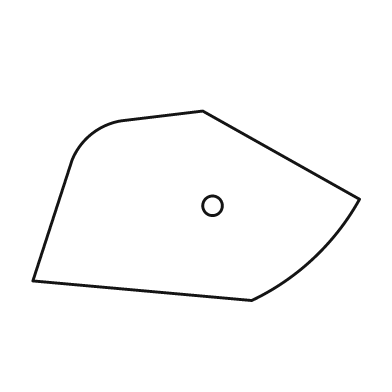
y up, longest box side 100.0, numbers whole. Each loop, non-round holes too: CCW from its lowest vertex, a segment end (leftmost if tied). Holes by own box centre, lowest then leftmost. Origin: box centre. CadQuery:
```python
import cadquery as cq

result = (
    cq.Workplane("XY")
    .moveTo(17.0, -29.0)
    .threePointArc((36.0, -16.0), (50.0, 2.0))
    .lineTo(2.0, 29.0)
    .lineTo(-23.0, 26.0)
    .threePointArc((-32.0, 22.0), (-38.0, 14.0))
    .lineTo(-50.0, -23.0)
    .close()
    .moveTo(5.0, 0.0)
    .circle(3.0)
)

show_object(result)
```